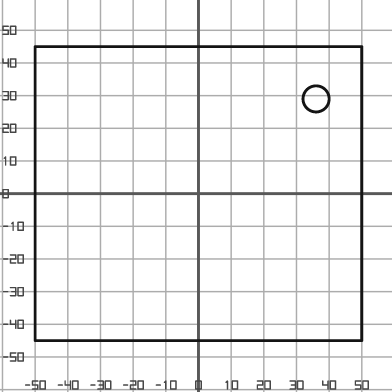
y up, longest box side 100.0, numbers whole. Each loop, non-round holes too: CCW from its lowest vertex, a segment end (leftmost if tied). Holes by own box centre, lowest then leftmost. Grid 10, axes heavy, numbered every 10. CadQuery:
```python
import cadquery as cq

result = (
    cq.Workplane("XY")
    .moveTo(-50.0, -45.0)
    .lineTo(50.0, -45.0)
    .lineTo(50.0, 45.0)
    .lineTo(-50.0, 45.0)
    .close()
    .moveTo(36.0, 29.0)
    .circle(4.0)
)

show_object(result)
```